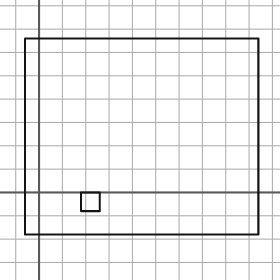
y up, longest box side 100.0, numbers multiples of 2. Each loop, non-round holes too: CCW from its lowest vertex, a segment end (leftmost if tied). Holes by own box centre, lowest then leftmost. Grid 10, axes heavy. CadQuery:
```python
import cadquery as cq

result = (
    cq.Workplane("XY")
    .moveTo(-6.0, -18.0)
    .lineTo(94.0, -18.0)
    .lineTo(94.0, 66.0)
    .lineTo(-6.0, 66.0)
    .close()
    .moveTo(18.0, -8.0)
    .lineTo(26.0, -8.0)
    .lineTo(26.0, 0.0)
    .lineTo(18.0, 0.0)
    .close()
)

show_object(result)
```